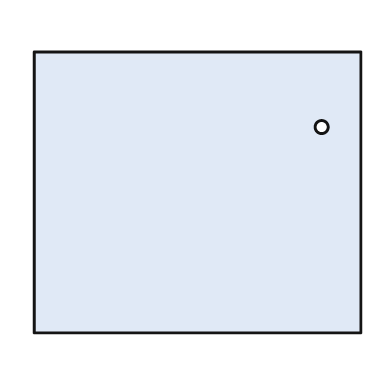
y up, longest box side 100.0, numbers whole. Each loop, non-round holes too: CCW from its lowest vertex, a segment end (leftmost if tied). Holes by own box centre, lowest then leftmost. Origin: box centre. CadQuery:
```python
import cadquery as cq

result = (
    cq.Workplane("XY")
    .moveTo(-50.0, -43.0)
    .lineTo(50.0, -43.0)
    .lineTo(50.0, 43.0)
    .lineTo(-50.0, 43.0)
    .close()
    .moveTo(38.0, 20.0)
    .circle(2.0)
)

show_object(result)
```